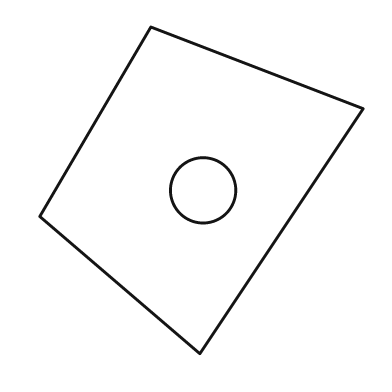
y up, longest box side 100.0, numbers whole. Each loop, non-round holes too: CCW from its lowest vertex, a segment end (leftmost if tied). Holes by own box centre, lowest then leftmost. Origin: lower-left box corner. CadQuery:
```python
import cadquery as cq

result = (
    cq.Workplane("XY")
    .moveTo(49.0, 0.0)
    .lineTo(99.0, 75.0)
    .lineTo(34.0, 100.0)
    .lineTo(0.0, 42.0)
    .close()
    .moveTo(50.0, 50.0)
    .circle(10.0)
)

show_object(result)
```